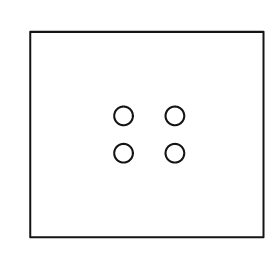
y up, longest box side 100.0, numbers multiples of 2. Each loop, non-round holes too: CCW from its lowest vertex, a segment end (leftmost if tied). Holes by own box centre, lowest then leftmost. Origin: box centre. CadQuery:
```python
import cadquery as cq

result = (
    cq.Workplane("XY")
    .moveTo(-50.0, -44.0)
    .lineTo(50.0, -44.0)
    .lineTo(50.0, 44.0)
    .lineTo(-50.0, 44.0)
    .close()
    .moveTo(-10.0, -8.0)
    .circle(4.0)
    .moveTo(12.0, -8.0)
    .circle(4.0)
    .moveTo(-10.0, 8.0)
    .circle(4.0)
    .moveTo(12.0, 8.0)
    .circle(4.0)
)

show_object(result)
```